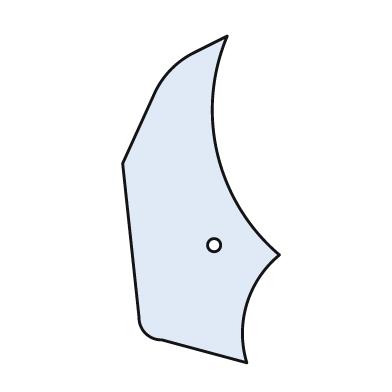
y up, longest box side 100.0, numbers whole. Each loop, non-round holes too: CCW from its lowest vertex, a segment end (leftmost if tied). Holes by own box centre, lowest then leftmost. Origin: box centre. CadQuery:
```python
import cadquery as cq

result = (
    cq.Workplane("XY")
    .moveTo(14.0, -50.0)
    .threePointArc((14.0, -32.0), (24.0, -17.0))
    .threePointArc((5.0, 14.0), (8.0, 50.0))
    .lineTo(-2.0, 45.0)
    .threePointArc((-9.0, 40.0), (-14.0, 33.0))
    .lineTo(-24.0, 11.0)
    .lineTo(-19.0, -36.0)
    .threePointArc((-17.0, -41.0), (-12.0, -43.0))
    .close()
    .moveTo(4.0, -14.0)
    .circle(2.0)
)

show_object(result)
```